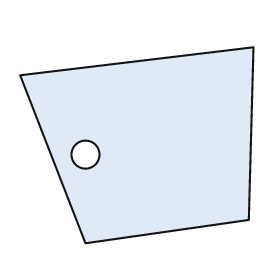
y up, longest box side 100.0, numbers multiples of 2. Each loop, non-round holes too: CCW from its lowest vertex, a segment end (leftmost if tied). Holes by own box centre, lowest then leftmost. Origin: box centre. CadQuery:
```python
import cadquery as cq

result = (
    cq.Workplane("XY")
    .moveTo(-22.0, -42.0)
    .lineTo(48.0, -32.0)
    .lineTo(50.0, 42.0)
    .lineTo(-50.0, 30.0)
    .close()
    .moveTo(-22.0, -4.0)
    .circle(6.0)
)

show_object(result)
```